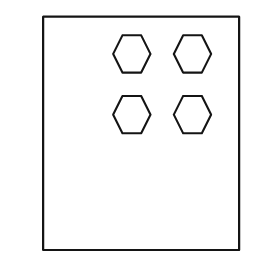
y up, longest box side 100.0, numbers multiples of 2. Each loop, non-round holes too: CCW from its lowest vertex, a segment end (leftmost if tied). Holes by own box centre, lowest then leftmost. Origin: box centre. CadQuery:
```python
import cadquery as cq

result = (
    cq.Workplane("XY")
    .moveTo(-42.0, -50.0)
    .lineTo(42.0, -50.0)
    .lineTo(42.0, 50.0)
    .lineTo(-42.0, 50.0)
    .close()
    .moveTo(-8.0, 0.0)
    .lineTo(0.0, 0.0)
    .lineTo(4.0, 8.0)
    .lineTo(0.0, 16.0)
    .lineTo(-8.0, 16.0)
    .lineTo(-12.0, 8.0)
    .close()
    .moveTo(18.0, 0.0)
    .lineTo(26.0, 0.0)
    .lineTo(30.0, 8.0)
    .lineTo(26.0, 16.0)
    .lineTo(18.0, 16.0)
    .lineTo(14.0, 8.0)
    .close()
    .moveTo(-8.0, 26.0)
    .lineTo(0.0, 26.0)
    .lineTo(4.0, 34.0)
    .lineTo(0.0, 42.0)
    .lineTo(-8.0, 42.0)
    .lineTo(-12.0, 34.0)
    .close()
    .moveTo(18.0, 26.0)
    .lineTo(26.0, 26.0)
    .lineTo(30.0, 34.0)
    .lineTo(26.0, 42.0)
    .lineTo(18.0, 42.0)
    .lineTo(14.0, 34.0)
    .close()
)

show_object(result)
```